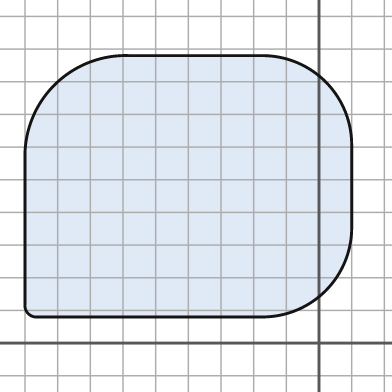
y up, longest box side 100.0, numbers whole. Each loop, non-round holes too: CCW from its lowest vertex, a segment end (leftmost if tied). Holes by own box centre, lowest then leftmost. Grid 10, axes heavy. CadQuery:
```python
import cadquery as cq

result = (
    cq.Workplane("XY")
    .moveTo(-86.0, 8.0)
    .lineTo(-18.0, 8.0)
    .threePointArc((2.0, 16.0), (10.0, 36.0))
    .lineTo(10.0, 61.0)
    .threePointArc((2.0, 80.0), (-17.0, 88.0))
    .lineTo(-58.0, 88.0)
    .threePointArc((-81.0, 79.0), (-90.0, 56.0))
    .lineTo(-90.0, 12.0)
    .threePointArc((-89.0, 9.0), (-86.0, 8.0))
    .close()
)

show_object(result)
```